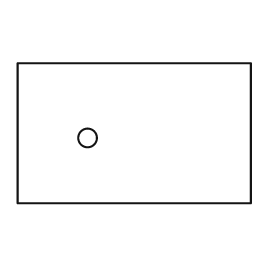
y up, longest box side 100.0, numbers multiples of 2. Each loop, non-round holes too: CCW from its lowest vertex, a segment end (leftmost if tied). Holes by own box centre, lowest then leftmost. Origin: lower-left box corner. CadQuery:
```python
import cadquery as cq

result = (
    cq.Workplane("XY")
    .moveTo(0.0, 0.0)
    .lineTo(100.0, 0.0)
    .lineTo(100.0, 60.0)
    .lineTo(0.0, 60.0)
    .close()
    .moveTo(30.0, 28.0)
    .circle(4.0)
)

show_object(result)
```